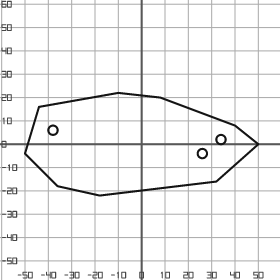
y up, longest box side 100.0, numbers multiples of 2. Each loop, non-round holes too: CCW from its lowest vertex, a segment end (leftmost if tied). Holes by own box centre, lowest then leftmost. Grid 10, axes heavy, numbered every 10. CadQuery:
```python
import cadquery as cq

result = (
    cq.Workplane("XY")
    .moveTo(-18.0, -22.0)
    .lineTo(32.0, -16.0)
    .lineTo(50.0, 0.0)
    .lineTo(40.0, 8.0)
    .lineTo(8.0, 20.0)
    .lineTo(-10.0, 22.0)
    .lineTo(-44.0, 16.0)
    .lineTo(-50.0, -4.0)
    .lineTo(-36.0, -18.0)
    .close()
    .moveTo(26.0, -4.0)
    .circle(2.0)
    .moveTo(34.0, 2.0)
    .circle(2.0)
    .moveTo(-38.0, 6.0)
    .circle(2.0)
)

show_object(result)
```